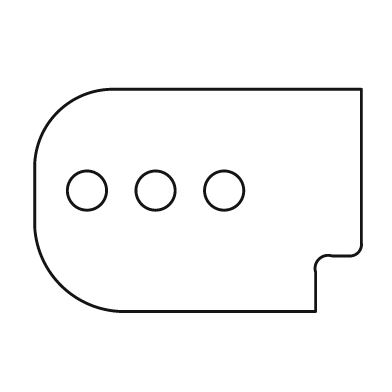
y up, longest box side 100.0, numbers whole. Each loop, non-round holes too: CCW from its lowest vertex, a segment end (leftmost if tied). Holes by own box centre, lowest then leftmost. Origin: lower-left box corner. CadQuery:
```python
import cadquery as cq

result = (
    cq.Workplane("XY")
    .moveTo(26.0, 0.0)
    .lineTo(86.0, 0.0)
    .lineTo(86.0, 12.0)
    .threePointArc((87.0, 16.0), (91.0, 17.0))
    .lineTo(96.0, 17.0)
    .threePointArc((99.0, 18.0), (100.0, 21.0))
    .lineTo(100.0, 68.0)
    .lineTo(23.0, 68.0)
    .threePointArc((7.0, 61.0), (0.0, 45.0))
    .lineTo(0.0, 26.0)
    .threePointArc((8.0, 8.0), (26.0, 0.0))
    .close()
    .moveTo(16.0, 37.0)
    .circle(6.0)
    .moveTo(37.0, 37.0)
    .circle(6.0)
    .moveTo(58.0, 37.0)
    .circle(6.0)
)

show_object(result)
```